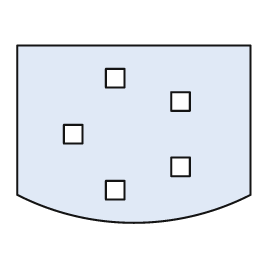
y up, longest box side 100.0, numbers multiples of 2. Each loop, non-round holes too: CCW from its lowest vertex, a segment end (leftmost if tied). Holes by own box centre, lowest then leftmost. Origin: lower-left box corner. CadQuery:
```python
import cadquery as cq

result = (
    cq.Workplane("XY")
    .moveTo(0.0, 12.0)
    .threePointArc((50.0, 0.0), (100.0, 12.0))
    .lineTo(100.0, 76.0)
    .lineTo(0.0, 76.0)
    .close()
    .moveTo(38.0, 10.0)
    .lineTo(46.0, 10.0)
    .lineTo(46.0, 18.0)
    .lineTo(38.0, 18.0)
    .close()
    .moveTo(66.0, 20.0)
    .lineTo(74.0, 20.0)
    .lineTo(74.0, 28.0)
    .lineTo(66.0, 28.0)
    .close()
    .moveTo(20.0, 34.0)
    .lineTo(28.0, 34.0)
    .lineTo(28.0, 42.0)
    .lineTo(20.0, 42.0)
    .close()
    .moveTo(66.0, 48.0)
    .lineTo(74.0, 48.0)
    .lineTo(74.0, 56.0)
    .lineTo(66.0, 56.0)
    .close()
    .moveTo(38.0, 58.0)
    .lineTo(46.0, 58.0)
    .lineTo(46.0, 66.0)
    .lineTo(38.0, 66.0)
    .close()
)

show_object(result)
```